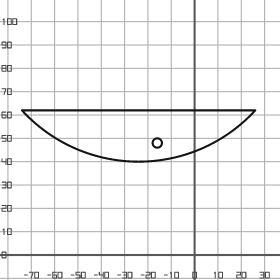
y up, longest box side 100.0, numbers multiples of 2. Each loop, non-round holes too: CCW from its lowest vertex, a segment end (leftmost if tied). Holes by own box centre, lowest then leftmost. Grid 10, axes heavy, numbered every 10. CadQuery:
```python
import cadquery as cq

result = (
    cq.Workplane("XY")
    .moveTo(-74.0, 62.0)
    .threePointArc((-24.0, 40.0), (26.0, 62.0))
    .close()
    .moveTo(-16.0, 48.0)
    .circle(2.0)
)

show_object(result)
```